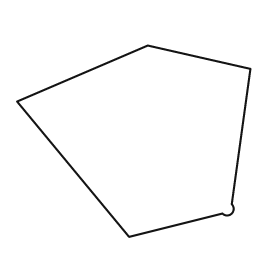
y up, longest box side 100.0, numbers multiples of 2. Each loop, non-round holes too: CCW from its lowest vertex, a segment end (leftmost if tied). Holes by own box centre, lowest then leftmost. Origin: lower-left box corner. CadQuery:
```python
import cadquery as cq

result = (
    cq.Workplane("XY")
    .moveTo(48.0, 0.0)
    .lineTo(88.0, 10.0)
    .threePointArc((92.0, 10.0), (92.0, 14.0))
    .lineTo(100.0, 72.0)
    .lineTo(56.0, 82.0)
    .lineTo(0.0, 58.0)
    .close()
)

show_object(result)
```